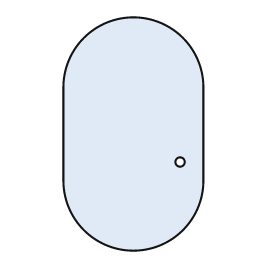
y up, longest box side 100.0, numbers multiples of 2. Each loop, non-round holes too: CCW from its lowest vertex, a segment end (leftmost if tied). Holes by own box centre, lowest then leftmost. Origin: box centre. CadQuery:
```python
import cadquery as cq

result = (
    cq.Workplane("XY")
    .moveTo(-30.0, -20.0)
    .threePointArc((0.0, -50.0), (30.0, -20.0))
    .lineTo(30.0, 20.0)
    .threePointArc((0.0, 50.0), (-30.0, 20.0))
    .close()
    .moveTo(20.0, -12.0)
    .circle(2.0)
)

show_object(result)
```